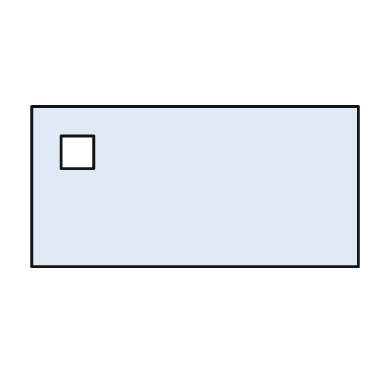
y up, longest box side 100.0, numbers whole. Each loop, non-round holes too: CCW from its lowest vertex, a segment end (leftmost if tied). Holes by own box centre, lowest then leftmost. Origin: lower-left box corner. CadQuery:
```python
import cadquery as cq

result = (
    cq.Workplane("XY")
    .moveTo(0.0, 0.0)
    .lineTo(100.0, 0.0)
    .lineTo(100.0, 49.0)
    .lineTo(0.0, 49.0)
    .close()
    .moveTo(9.0, 30.0)
    .lineTo(19.0, 30.0)
    .lineTo(19.0, 40.0)
    .lineTo(9.0, 40.0)
    .close()
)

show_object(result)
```